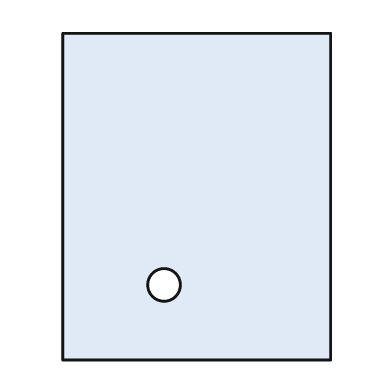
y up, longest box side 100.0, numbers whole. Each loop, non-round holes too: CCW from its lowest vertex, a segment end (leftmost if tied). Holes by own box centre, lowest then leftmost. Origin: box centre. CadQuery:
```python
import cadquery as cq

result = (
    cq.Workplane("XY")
    .moveTo(-41.0, -50.0)
    .lineTo(41.0, -50.0)
    .lineTo(41.0, 50.0)
    .lineTo(-41.0, 50.0)
    .close()
    .moveTo(-10.0, -27.0)
    .circle(5.0)
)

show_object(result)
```